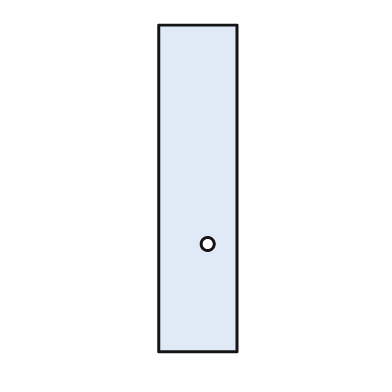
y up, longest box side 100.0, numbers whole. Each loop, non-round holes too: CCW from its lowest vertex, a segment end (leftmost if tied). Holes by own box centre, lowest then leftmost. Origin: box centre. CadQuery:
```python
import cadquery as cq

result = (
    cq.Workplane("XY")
    .moveTo(-12.0, -50.0)
    .lineTo(12.0, -50.0)
    .lineTo(12.0, 50.0)
    .lineTo(-12.0, 50.0)
    .close()
    .moveTo(3.0, -17.0)
    .circle(2.0)
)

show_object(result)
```